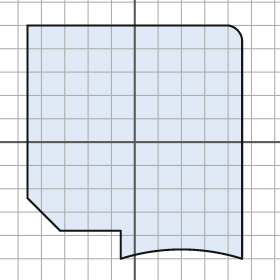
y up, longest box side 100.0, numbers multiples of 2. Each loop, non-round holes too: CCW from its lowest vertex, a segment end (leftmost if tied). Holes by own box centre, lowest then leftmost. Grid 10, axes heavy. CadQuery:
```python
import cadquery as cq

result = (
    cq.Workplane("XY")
    .moveTo(-6.0, -50.0)
    .threePointArc((20.0, -46.0), (46.0, -50.0))
    .lineTo(46.0, 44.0)
    .threePointArc((44.0, 48.0), (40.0, 50.0))
    .lineTo(-46.0, 50.0)
    .lineTo(-46.0, -24.0)
    .lineTo(-32.0, -38.0)
    .lineTo(-6.0, -38.0)
    .close()
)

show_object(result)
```